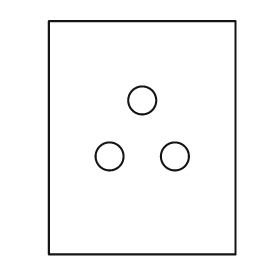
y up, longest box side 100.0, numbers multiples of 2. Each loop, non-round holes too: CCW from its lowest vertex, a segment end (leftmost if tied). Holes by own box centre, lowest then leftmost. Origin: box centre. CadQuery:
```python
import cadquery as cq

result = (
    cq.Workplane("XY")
    .moveTo(-40.0, -50.0)
    .lineTo(40.0, -50.0)
    .lineTo(40.0, 50.0)
    .lineTo(-40.0, 50.0)
    .close()
    .moveTo(-14.0, -8.0)
    .circle(6.0)
    .moveTo(14.0, -8.0)
    .circle(6.0)
    .moveTo(0.0, 16.0)
    .circle(6.0)
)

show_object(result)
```